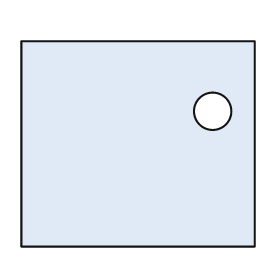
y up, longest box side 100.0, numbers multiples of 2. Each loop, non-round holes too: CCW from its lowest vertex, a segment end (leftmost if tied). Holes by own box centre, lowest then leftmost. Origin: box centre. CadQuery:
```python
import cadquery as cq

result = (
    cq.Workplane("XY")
    .moveTo(-50.0, -44.0)
    .lineTo(50.0, -44.0)
    .lineTo(50.0, 44.0)
    .lineTo(-50.0, 44.0)
    .close()
    .moveTo(32.0, 14.0)
    .circle(8.0)
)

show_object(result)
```